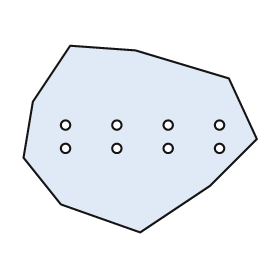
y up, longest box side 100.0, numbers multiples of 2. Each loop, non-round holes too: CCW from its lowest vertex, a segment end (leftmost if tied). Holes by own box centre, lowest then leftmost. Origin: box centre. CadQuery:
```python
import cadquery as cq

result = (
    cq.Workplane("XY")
    .moveTo(0.0, -40.0)
    .lineTo(30.0, -20.0)
    .lineTo(50.0, 0.0)
    .lineTo(38.0, 26.0)
    .lineTo(-2.0, 38.0)
    .lineTo(-30.0, 40.0)
    .lineTo(-46.0, 16.0)
    .lineTo(-50.0, -8.0)
    .lineTo(-34.0, -28.0)
    .close()
    .moveTo(-32.0, -4.0)
    .circle(2.0)
    .moveTo(-10.0, -4.0)
    .circle(2.0)
    .moveTo(12.0, -4.0)
    .circle(2.0)
    .moveTo(34.0, -4.0)
    .circle(2.0)
    .moveTo(-32.0, 6.0)
    .circle(2.0)
    .moveTo(-10.0, 6.0)
    .circle(2.0)
    .moveTo(12.0, 6.0)
    .circle(2.0)
    .moveTo(34.0, 6.0)
    .circle(2.0)
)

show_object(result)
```